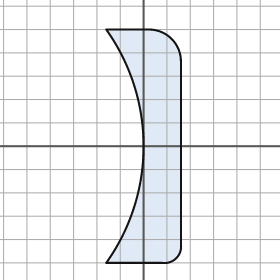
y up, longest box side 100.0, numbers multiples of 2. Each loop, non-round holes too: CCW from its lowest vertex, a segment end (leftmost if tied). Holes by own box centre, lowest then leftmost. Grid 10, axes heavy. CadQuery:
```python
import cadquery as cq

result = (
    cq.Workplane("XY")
    .moveTo(-16.0, -50.0)
    .lineTo(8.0, -50.0)
    .threePointArc((14.0, -48.0), (16.0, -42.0))
    .lineTo(16.0, 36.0)
    .threePointArc((12.0, 46.0), (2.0, 50.0))
    .lineTo(-16.0, 50.0)
    .threePointArc((0.0, 0.0), (-16.0, -50.0))
    .close()
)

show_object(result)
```